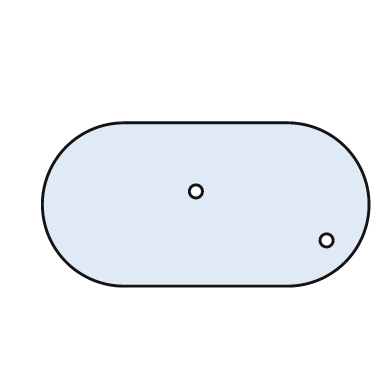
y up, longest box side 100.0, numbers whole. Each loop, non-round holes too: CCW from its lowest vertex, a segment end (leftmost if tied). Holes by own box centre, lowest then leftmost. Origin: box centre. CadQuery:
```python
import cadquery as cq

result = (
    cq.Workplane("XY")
    .moveTo(-25.0, -25.0)
    .lineTo(25.0, -25.0)
    .threePointArc((50.0, 0.0), (25.0, 25.0))
    .lineTo(-25.0, 25.0)
    .threePointArc((-50.0, 0.0), (-25.0, -25.0))
    .close()
    .moveTo(37.0, -11.0)
    .circle(2.0)
    .moveTo(-3.0, 4.0)
    .circle(2.0)
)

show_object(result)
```